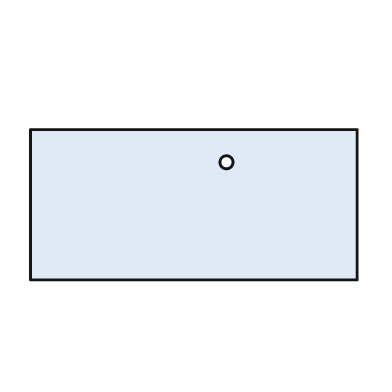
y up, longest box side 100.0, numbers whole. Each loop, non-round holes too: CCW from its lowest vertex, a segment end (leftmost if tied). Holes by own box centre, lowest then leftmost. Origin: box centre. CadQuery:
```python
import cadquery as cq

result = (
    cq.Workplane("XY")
    .moveTo(-50.0, -23.0)
    .lineTo(50.0, -23.0)
    .lineTo(50.0, 23.0)
    .lineTo(-50.0, 23.0)
    .close()
    .moveTo(10.0, 13.0)
    .circle(2.0)
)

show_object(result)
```